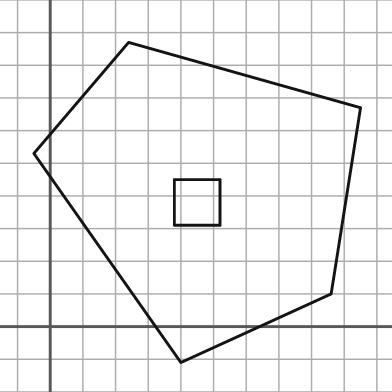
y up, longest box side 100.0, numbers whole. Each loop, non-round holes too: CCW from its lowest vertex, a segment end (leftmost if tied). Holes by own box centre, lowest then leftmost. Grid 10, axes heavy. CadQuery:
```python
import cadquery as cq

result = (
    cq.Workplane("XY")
    .moveTo(40.0, -11.0)
    .lineTo(86.0, 10.0)
    .lineTo(95.0, 67.0)
    .lineTo(24.0, 87.0)
    .lineTo(-5.0, 53.0)
    .close()
    .moveTo(38.0, 31.0)
    .lineTo(52.0, 31.0)
    .lineTo(52.0, 45.0)
    .lineTo(38.0, 45.0)
    .close()
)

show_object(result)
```